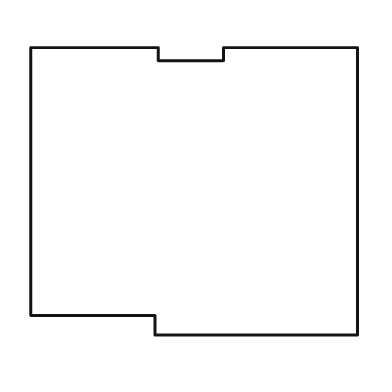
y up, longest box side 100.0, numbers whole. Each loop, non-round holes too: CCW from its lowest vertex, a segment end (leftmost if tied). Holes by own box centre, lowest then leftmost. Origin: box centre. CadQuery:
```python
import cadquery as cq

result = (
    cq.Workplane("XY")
    .moveTo(-12.0, -44.0)
    .lineTo(50.0, -44.0)
    .lineTo(50.0, 44.0)
    .lineTo(9.0, 44.0)
    .lineTo(9.0, 40.0)
    .lineTo(-11.0, 40.0)
    .lineTo(-11.0, 44.0)
    .lineTo(-50.0, 44.0)
    .lineTo(-50.0, -38.0)
    .lineTo(-12.0, -38.0)
    .close()
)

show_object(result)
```